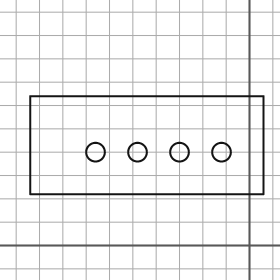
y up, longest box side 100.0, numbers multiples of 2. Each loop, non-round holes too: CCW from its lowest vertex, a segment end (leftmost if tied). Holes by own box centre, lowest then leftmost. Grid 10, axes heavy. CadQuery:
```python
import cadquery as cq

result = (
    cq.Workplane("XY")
    .moveTo(-94.0, 22.0)
    .lineTo(6.0, 22.0)
    .lineTo(6.0, 64.0)
    .lineTo(-94.0, 64.0)
    .close()
    .moveTo(-66.0, 40.0)
    .circle(4.0)
    .moveTo(-48.0, 40.0)
    .circle(4.0)
    .moveTo(-30.0, 40.0)
    .circle(4.0)
    .moveTo(-12.0, 40.0)
    .circle(4.0)
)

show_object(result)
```